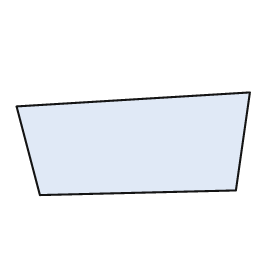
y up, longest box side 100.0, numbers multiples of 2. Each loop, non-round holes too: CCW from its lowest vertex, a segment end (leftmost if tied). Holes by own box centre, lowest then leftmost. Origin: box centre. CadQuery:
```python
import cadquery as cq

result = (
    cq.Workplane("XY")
    .moveTo(-40.0, -22.0)
    .lineTo(44.0, -20.0)
    .lineTo(50.0, 22.0)
    .lineTo(-50.0, 16.0)
    .close()
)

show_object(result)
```